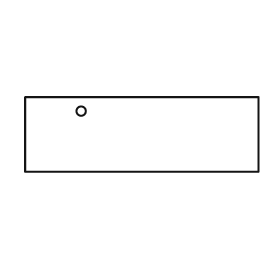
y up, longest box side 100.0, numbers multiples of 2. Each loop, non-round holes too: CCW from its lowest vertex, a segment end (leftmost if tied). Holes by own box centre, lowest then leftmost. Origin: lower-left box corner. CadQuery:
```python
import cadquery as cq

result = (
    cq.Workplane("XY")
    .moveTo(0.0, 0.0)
    .lineTo(100.0, 0.0)
    .lineTo(100.0, 32.0)
    .lineTo(0.0, 32.0)
    .close()
    .moveTo(24.0, 26.0)
    .circle(2.0)
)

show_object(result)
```